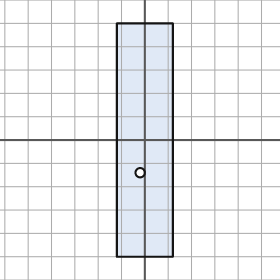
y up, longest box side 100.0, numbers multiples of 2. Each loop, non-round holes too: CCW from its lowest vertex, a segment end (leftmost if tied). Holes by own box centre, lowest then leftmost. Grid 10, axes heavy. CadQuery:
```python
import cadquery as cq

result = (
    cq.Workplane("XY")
    .moveTo(-12.0, -50.0)
    .lineTo(12.0, -50.0)
    .lineTo(12.0, 50.0)
    .lineTo(-12.0, 50.0)
    .close()
    .moveTo(-2.0, -14.0)
    .circle(2.0)
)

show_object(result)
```